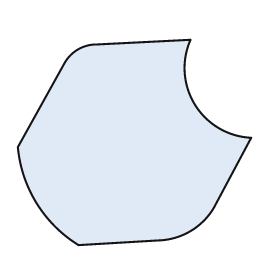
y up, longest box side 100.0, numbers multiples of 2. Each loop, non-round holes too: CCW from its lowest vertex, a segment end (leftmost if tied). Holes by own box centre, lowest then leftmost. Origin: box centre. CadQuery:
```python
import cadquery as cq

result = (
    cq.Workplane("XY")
    .moveTo(-24.0, -44.0)
    .lineTo(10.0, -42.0)
    .threePointArc((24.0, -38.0), (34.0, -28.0))
    .lineTo(50.0, 2.0)
    .threePointArc((26.0, 16.0), (24.0, 44.0))
    .lineTo(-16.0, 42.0)
    .threePointArc((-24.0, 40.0), (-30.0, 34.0))
    .lineTo(-50.0, -2.0)
    .threePointArc((-42.0, -26.0), (-24.0, -44.0))
    .close()
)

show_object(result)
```